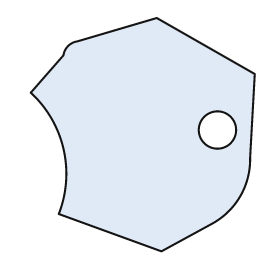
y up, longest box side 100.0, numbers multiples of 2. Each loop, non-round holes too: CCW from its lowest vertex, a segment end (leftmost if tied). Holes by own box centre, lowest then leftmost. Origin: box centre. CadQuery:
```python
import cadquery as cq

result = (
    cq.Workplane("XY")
    .moveTo(8.0, -50.0)
    .lineTo(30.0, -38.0)
    .threePointArc((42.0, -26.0), (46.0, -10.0))
    .lineTo(48.0, 26.0)
    .lineTo(6.0, 50.0)
    .lineTo(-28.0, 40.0)
    .threePointArc((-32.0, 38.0), (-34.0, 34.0))
    .lineTo(-48.0, 18.0)
    .threePointArc((-34.0, -6.0), (-36.0, -34.0))
    .close()
    .moveTo(32.0, 2.0)
    .circle(8.0)
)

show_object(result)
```